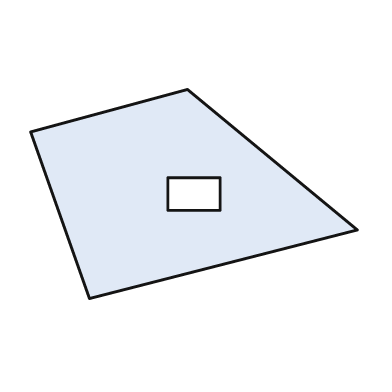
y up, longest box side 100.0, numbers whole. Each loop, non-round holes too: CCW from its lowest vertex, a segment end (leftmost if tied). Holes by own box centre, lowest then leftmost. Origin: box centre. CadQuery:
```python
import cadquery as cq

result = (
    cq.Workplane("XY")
    .moveTo(-32.0, -32.0)
    .lineTo(50.0, -11.0)
    .lineTo(-2.0, 32.0)
    .lineTo(-50.0, 19.0)
    .close()
    .moveTo(-8.0, -5.0)
    .lineTo(8.0, -5.0)
    .lineTo(8.0, 5.0)
    .lineTo(-8.0, 5.0)
    .close()
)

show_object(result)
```